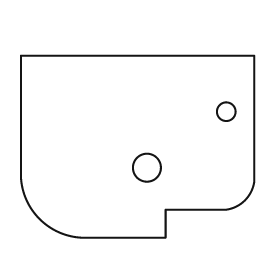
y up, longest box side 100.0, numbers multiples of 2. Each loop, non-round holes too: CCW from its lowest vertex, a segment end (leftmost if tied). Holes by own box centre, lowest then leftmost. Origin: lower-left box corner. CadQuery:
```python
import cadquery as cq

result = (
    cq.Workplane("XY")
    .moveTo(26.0, 0.0)
    .lineTo(62.0, 0.0)
    .lineTo(62.0, 12.0)
    .lineTo(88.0, 12.0)
    .threePointArc((96.0, 16.0), (100.0, 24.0))
    .lineTo(100.0, 78.0)
    .lineTo(0.0, 78.0)
    .lineTo(0.0, 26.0)
    .threePointArc((8.0, 8.0), (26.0, 0.0))
    .close()
    .moveTo(54.0, 30.0)
    .circle(6.0)
    .moveTo(88.0, 54.0)
    .circle(4.0)
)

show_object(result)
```